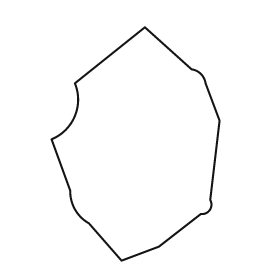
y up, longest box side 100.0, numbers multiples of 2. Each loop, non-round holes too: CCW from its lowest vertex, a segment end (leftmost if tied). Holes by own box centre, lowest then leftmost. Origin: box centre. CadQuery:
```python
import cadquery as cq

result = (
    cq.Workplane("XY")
    .moveTo(-6.0, -50.0)
    .lineTo(10.0, -44.0)
    .lineTo(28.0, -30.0)
    .threePointArc((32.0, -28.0), (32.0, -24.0))
    .lineTo(36.0, 10.0)
    .lineTo(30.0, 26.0)
    .threePointArc((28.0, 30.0), (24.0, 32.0))
    .lineTo(4.0, 50.0)
    .lineTo(-26.0, 26.0)
    .threePointArc((-26.0, 12.0), (-36.0, 2.0))
    .lineTo(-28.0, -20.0)
    .threePointArc((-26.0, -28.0), (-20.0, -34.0))
    .close()
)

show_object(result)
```